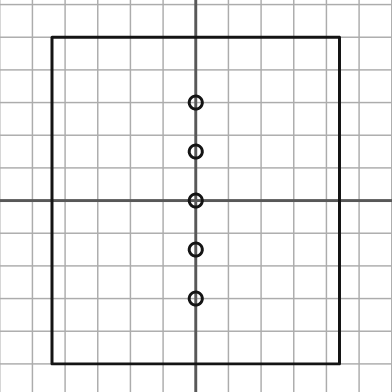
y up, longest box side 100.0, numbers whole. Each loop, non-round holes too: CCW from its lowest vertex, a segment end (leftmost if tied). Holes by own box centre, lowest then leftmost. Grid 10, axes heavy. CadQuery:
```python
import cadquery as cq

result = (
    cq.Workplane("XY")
    .moveTo(-44.0, -50.0)
    .lineTo(44.0, -50.0)
    .lineTo(44.0, 50.0)
    .lineTo(-44.0, 50.0)
    .close()
    .moveTo(0.0, -30.0)
    .circle(2.0)
    .moveTo(0.0, -15.0)
    .circle(2.0)
    .moveTo(0.0, 0.0)
    .circle(2.0)
    .moveTo(0.0, 15.0)
    .circle(2.0)
    .moveTo(0.0, 30.0)
    .circle(2.0)
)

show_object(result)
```